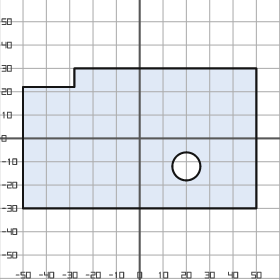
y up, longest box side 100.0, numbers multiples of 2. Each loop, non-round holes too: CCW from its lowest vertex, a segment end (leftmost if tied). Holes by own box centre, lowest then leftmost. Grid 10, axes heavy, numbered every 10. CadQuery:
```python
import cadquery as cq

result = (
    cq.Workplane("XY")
    .moveTo(-50.0, -30.0)
    .lineTo(50.0, -30.0)
    .lineTo(50.0, 30.0)
    .lineTo(-28.0, 30.0)
    .lineTo(-28.0, 22.0)
    .lineTo(-50.0, 22.0)
    .close()
    .moveTo(20.0, -12.0)
    .circle(6.0)
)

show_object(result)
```